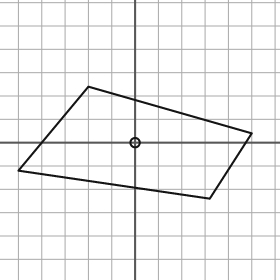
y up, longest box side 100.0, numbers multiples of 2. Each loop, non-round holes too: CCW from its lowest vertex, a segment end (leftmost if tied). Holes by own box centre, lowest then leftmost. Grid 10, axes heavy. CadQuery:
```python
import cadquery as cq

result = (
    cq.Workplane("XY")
    .moveTo(32.0, -24.0)
    .lineTo(50.0, 4.0)
    .lineTo(-20.0, 24.0)
    .lineTo(-50.0, -12.0)
    .close()
    .moveTo(0.0, 0.0)
    .circle(2.0)
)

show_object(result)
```